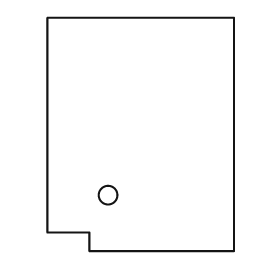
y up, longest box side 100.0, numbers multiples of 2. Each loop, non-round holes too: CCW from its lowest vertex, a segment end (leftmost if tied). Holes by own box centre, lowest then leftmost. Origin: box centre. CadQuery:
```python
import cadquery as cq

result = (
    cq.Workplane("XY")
    .moveTo(-22.0, -50.0)
    .lineTo(40.0, -50.0)
    .lineTo(40.0, 50.0)
    .lineTo(-40.0, 50.0)
    .lineTo(-40.0, -42.0)
    .lineTo(-22.0, -42.0)
    .close()
    .moveTo(-14.0, -26.0)
    .circle(4.0)
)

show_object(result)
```